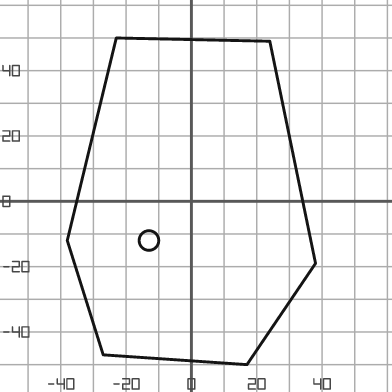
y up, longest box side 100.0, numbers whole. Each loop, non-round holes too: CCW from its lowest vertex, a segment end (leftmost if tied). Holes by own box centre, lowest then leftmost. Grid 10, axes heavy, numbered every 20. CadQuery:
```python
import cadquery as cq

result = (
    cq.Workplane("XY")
    .moveTo(17.0, -50.0)
    .lineTo(38.0, -19.0)
    .lineTo(24.0, 49.0)
    .lineTo(-23.0, 50.0)
    .lineTo(-38.0, -12.0)
    .lineTo(-27.0, -47.0)
    .close()
    .moveTo(-13.0, -12.0)
    .circle(3.0)
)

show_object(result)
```